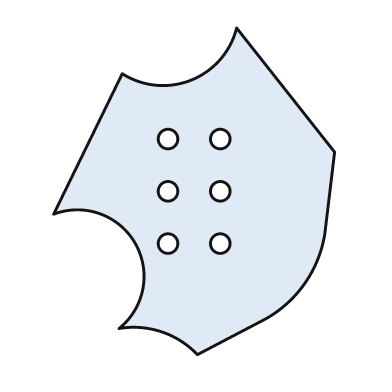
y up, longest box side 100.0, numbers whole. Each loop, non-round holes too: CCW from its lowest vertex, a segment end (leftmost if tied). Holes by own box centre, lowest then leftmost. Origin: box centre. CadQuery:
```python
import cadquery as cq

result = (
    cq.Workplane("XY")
    .moveTo(1.0, -50.0)
    .lineTo(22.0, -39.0)
    .threePointArc((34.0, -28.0), (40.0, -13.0))
    .lineTo(43.0, 12.0)
    .lineTo(13.0, 50.0)
    .threePointArc((-1.0, 34.0), (-22.0, 36.0))
    .lineTo(-43.0, -7.0)
    .threePointArc((-18.0, -16.0), (-23.0, -42.0))
    .threePointArc((-10.0, -43.0), (1.0, -50.0))
    .close()
    .moveTo(-8.0, -16.0)
    .circle(3.0)
    .moveTo(8.0, -16.0)
    .circle(3.0)
    .moveTo(-8.0, 0.0)
    .circle(3.0)
    .moveTo(8.0, 0.0)
    .circle(3.0)
    .moveTo(-8.0, 16.0)
    .circle(3.0)
    .moveTo(8.0, 16.0)
    .circle(3.0)
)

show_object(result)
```